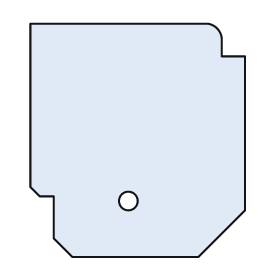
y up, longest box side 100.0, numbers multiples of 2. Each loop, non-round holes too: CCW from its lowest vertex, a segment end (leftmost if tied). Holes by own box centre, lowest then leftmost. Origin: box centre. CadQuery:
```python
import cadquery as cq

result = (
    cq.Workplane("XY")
    .moveTo(-28.0, -50.0)
    .lineTo(26.0, -50.0)
    .lineTo(46.0, -30.0)
    .lineTo(46.0, 36.0)
    .lineTo(36.0, 36.0)
    .lineTo(36.0, 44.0)
    .threePointArc((34.0, 48.0), (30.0, 50.0))
    .lineTo(-46.0, 50.0)
    .lineTo(-46.0, -20.0)
    .lineTo(-42.0, -24.0)
    .lineTo(-36.0, -24.0)
    .lineTo(-36.0, -42.0)
    .close()
    .moveTo(-4.0, -26.0)
    .circle(4.0)
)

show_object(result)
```